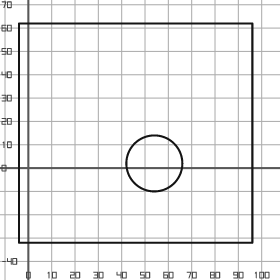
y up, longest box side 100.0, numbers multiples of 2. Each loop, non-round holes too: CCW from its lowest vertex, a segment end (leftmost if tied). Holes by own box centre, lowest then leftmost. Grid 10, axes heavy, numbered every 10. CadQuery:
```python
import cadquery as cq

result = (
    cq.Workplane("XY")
    .moveTo(-4.0, -32.0)
    .lineTo(96.0, -32.0)
    .lineTo(96.0, 62.0)
    .lineTo(-4.0, 62.0)
    .close()
    .moveTo(54.0, 2.0)
    .circle(12.0)
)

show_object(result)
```